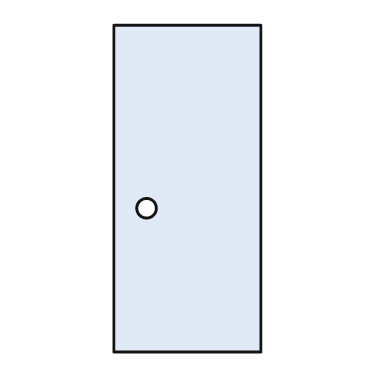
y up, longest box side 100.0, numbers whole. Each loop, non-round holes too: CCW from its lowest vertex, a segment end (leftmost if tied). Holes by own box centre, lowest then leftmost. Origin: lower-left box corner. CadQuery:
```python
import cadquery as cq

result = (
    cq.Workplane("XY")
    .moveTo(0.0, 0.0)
    .lineTo(45.0, 0.0)
    .lineTo(45.0, 100.0)
    .lineTo(0.0, 100.0)
    .close()
    .moveTo(10.0, 44.0)
    .circle(3.0)
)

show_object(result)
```